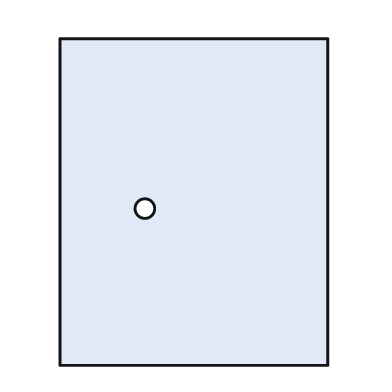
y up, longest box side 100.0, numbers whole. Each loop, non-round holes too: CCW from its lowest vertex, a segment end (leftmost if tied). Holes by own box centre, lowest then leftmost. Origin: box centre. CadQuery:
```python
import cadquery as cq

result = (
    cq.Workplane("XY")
    .moveTo(-41.0, -50.0)
    .lineTo(41.0, -50.0)
    .lineTo(41.0, 50.0)
    .lineTo(-41.0, 50.0)
    .close()
    .moveTo(-15.0, -2.0)
    .circle(3.0)
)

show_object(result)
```